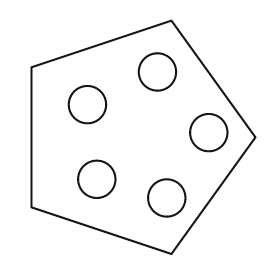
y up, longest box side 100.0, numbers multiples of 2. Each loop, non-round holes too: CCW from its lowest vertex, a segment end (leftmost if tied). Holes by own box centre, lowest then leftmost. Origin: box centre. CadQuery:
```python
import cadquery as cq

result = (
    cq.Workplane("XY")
    .moveTo(12.0, -50.0)
    .lineTo(48.0, 0.0)
    .lineTo(12.0, 50.0)
    .lineTo(-48.0, 30.0)
    .lineTo(-48.0, -30.0)
    .close()
    .moveTo(10.0, -26.0)
    .circle(8.0)
    .moveTo(-20.0, -18.0)
    .circle(8.0)
    .moveTo(28.0, 2.0)
    .circle(8.0)
    .moveTo(-24.0, 14.0)
    .circle(8.0)
    .moveTo(6.0, 28.0)
    .circle(8.0)
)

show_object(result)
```